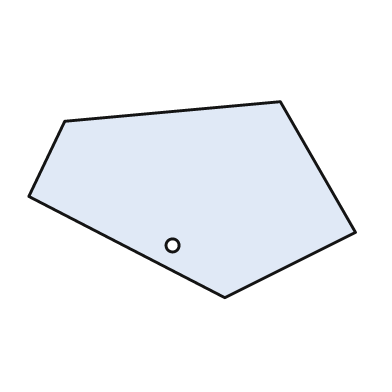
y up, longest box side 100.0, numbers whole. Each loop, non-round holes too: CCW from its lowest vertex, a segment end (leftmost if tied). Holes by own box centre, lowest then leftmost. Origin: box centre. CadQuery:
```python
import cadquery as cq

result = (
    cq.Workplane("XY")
    .moveTo(10.0, -30.0)
    .lineTo(50.0, -10.0)
    .lineTo(27.0, 30.0)
    .lineTo(-39.0, 24.0)
    .lineTo(-50.0, 1.0)
    .close()
    .moveTo(-6.0, -14.0)
    .circle(2.0)
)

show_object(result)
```